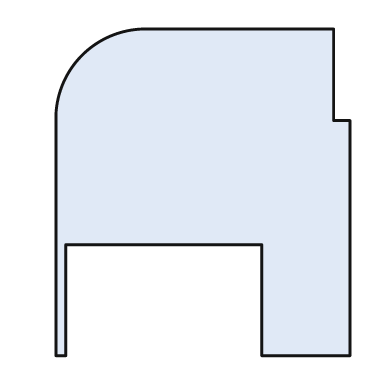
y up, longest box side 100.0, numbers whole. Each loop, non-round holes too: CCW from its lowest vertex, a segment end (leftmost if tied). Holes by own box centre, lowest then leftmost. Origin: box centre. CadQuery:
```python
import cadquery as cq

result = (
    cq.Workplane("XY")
    .moveTo(-45.0, -50.0)
    .lineTo(-42.0, -50.0)
    .lineTo(-42.0, -16.0)
    .lineTo(18.0, -16.0)
    .lineTo(18.0, -50.0)
    .lineTo(45.0, -50.0)
    .lineTo(45.0, 22.0)
    .lineTo(40.0, 22.0)
    .lineTo(40.0, 50.0)
    .lineTo(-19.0, 50.0)
    .threePointArc((-37.0, 42.0), (-45.0, 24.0))
    .close()
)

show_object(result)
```